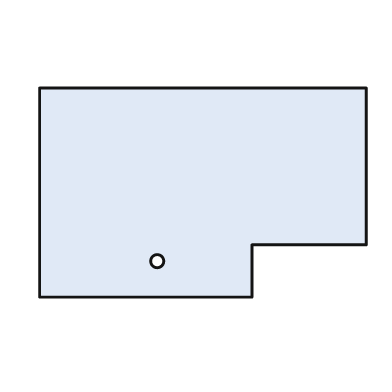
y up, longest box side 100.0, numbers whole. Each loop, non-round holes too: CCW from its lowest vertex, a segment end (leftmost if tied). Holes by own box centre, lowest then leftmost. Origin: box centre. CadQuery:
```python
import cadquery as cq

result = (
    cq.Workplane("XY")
    .moveTo(-50.0, -32.0)
    .lineTo(15.0, -32.0)
    .lineTo(15.0, -16.0)
    .lineTo(50.0, -16.0)
    .lineTo(50.0, 32.0)
    .lineTo(-50.0, 32.0)
    .close()
    .moveTo(-14.0, -21.0)
    .circle(2.0)
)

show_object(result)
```